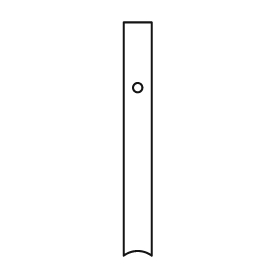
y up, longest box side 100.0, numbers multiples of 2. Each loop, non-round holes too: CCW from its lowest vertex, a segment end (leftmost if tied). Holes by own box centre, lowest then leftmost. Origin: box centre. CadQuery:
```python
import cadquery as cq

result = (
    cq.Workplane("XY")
    .moveTo(-6.0, -50.0)
    .threePointArc((0.0, -48.0), (6.0, -50.0))
    .lineTo(6.0, 50.0)
    .lineTo(-6.0, 50.0)
    .close()
    .moveTo(0.0, 22.0)
    .circle(2.0)
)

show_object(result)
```